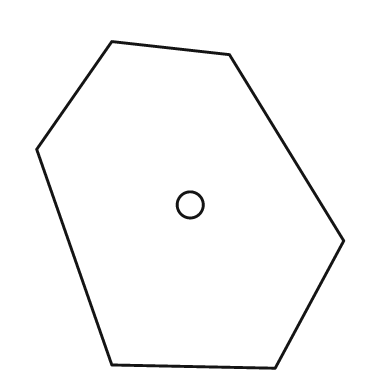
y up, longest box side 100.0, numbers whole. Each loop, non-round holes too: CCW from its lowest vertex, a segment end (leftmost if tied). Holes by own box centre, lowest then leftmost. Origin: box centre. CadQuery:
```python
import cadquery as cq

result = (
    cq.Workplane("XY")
    .moveTo(26.0, -50.0)
    .lineTo(47.0, -11.0)
    .lineTo(12.0, 46.0)
    .lineTo(-24.0, 50.0)
    .lineTo(-47.0, 17.0)
    .lineTo(-24.0, -49.0)
    .close()
    .moveTo(0.0, 0.0)
    .circle(4.0)
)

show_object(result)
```